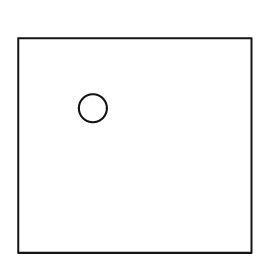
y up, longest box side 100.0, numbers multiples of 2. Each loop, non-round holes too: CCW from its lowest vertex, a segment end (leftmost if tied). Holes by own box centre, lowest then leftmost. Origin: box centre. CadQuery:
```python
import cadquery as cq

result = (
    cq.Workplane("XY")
    .moveTo(-50.0, -46.0)
    .lineTo(50.0, -46.0)
    .lineTo(50.0, 46.0)
    .lineTo(-50.0, 46.0)
    .close()
    .moveTo(-18.0, 16.0)
    .circle(6.0)
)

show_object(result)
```